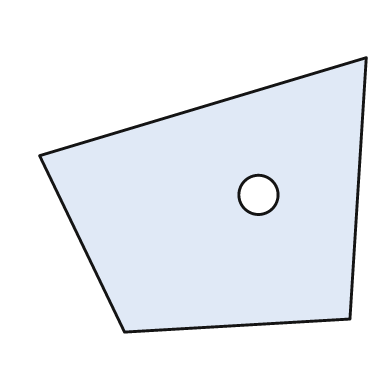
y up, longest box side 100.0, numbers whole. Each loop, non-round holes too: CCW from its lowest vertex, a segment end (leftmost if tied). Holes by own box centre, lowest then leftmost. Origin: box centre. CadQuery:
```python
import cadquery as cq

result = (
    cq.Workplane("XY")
    .moveTo(-24.0, -42.0)
    .lineTo(45.0, -38.0)
    .lineTo(50.0, 42.0)
    .lineTo(-50.0, 12.0)
    .close()
    .moveTo(17.0, 0.0)
    .circle(6.0)
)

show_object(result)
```